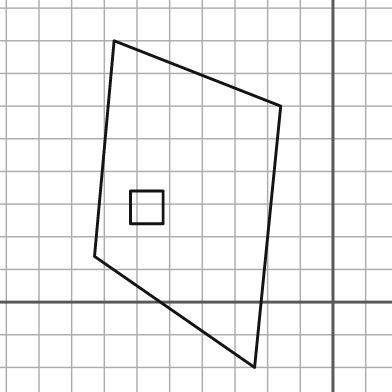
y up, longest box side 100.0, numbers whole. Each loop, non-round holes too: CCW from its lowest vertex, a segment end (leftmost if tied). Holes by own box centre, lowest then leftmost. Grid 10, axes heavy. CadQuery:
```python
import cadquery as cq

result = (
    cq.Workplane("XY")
    .moveTo(-24.0, -20.0)
    .lineTo(-16.0, 60.0)
    .lineTo(-67.0, 80.0)
    .lineTo(-73.0, 14.0)
    .close()
    .moveTo(-62.0, 24.0)
    .lineTo(-52.0, 24.0)
    .lineTo(-52.0, 34.0)
    .lineTo(-62.0, 34.0)
    .close()
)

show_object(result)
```